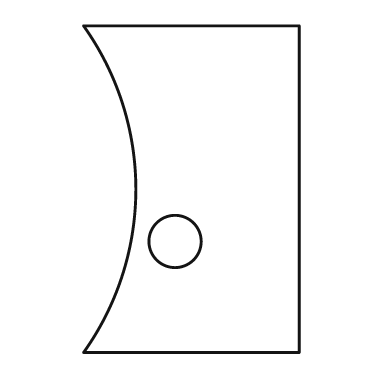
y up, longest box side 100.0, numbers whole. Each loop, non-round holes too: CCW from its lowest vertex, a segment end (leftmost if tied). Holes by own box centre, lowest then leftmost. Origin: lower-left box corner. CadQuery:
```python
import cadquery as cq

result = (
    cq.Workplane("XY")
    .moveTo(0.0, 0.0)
    .lineTo(66.0, 0.0)
    .lineTo(66.0, 100.0)
    .lineTo(0.0, 100.0)
    .threePointArc((16.0, 50.0), (0.0, 0.0))
    .close()
    .moveTo(28.0, 34.0)
    .circle(8.0)
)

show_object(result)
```